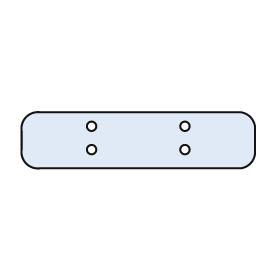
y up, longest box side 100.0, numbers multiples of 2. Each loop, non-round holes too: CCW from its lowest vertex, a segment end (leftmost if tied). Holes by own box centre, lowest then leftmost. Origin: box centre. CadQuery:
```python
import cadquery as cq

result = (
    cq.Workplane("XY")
    .moveTo(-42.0, -12.0)
    .lineTo(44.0, -12.0)
    .threePointArc((48.0, -10.0), (50.0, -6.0))
    .lineTo(50.0, 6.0)
    .threePointArc((48.0, 10.0), (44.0, 12.0))
    .lineTo(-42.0, 12.0)
    .threePointArc((-48.0, 10.0), (-50.0, 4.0))
    .lineTo(-50.0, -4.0)
    .threePointArc((-48.0, -10.0), (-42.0, -12.0))
    .close()
    .moveTo(-20.0, -4.0)
    .circle(2.0)
    .moveTo(20.0, -4.0)
    .circle(2.0)
    .moveTo(-20.0, 6.0)
    .circle(2.0)
    .moveTo(20.0, 6.0)
    .circle(2.0)
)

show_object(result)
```